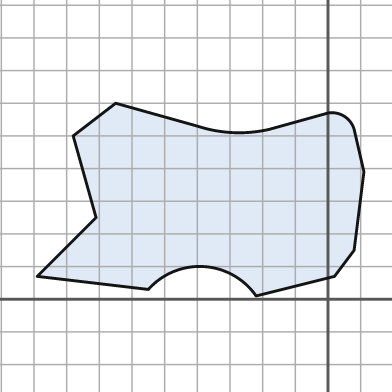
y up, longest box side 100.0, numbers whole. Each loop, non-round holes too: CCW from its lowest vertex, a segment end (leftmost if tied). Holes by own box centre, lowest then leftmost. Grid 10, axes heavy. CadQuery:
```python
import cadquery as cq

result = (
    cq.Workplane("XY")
    .moveTo(-22.0, 1.0)
    .lineTo(2.0, 7.0)
    .lineTo(8.0, 15.0)
    .lineTo(11.0, 39.0)
    .lineTo(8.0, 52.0)
    .threePointArc((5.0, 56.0), (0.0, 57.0))
    .lineTo(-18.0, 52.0)
    .threePointArc((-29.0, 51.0), (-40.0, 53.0))
    .lineTo(-65.0, 60.0)
    .lineTo(-78.0, 50.0)
    .lineTo(-71.0, 25.0)
    .lineTo(-89.0, 7.0)
    .lineTo(-55.0, 3.0)
    .threePointArc((-38.0, 10.0), (-22.0, 1.0))
    .close()
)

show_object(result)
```